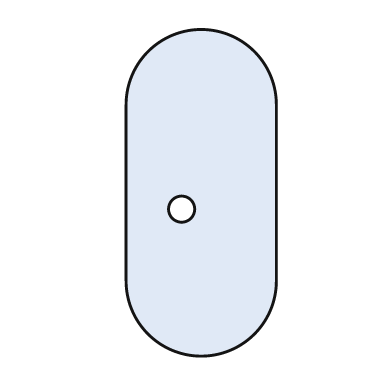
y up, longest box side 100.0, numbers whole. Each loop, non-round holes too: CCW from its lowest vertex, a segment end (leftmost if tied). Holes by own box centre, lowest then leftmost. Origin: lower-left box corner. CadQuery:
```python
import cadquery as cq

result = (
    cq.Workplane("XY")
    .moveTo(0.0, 23.0)
    .threePointArc((23.0, 0.0), (46.0, 23.0))
    .lineTo(46.0, 77.0)
    .threePointArc((23.0, 100.0), (0.0, 77.0))
    .close()
    .moveTo(17.0, 45.0)
    .circle(4.0)
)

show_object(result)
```